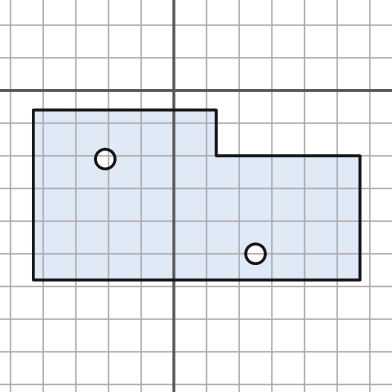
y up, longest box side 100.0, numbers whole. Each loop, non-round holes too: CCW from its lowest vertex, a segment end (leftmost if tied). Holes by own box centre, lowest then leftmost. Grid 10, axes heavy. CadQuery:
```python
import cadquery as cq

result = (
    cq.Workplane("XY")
    .moveTo(-43.0, -58.0)
    .lineTo(57.0, -58.0)
    .lineTo(57.0, -20.0)
    .lineTo(13.0, -20.0)
    .lineTo(13.0, -6.0)
    .lineTo(-43.0, -6.0)
    .close()
    .moveTo(25.0, -50.0)
    .circle(3.0)
    .moveTo(-21.0, -21.0)
    .circle(3.0)
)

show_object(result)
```